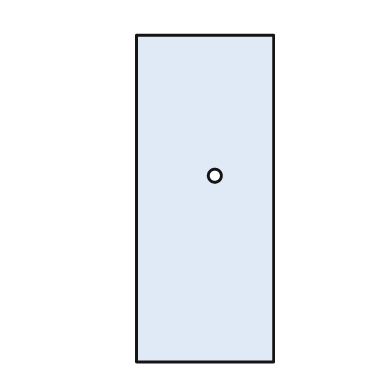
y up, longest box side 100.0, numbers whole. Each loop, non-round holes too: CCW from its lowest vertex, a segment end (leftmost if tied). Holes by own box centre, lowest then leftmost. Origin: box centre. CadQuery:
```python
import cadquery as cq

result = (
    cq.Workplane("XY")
    .moveTo(-21.0, -50.0)
    .lineTo(21.0, -50.0)
    .lineTo(21.0, 50.0)
    .lineTo(-21.0, 50.0)
    .close()
    .moveTo(3.0, 7.0)
    .circle(2.0)
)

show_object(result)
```